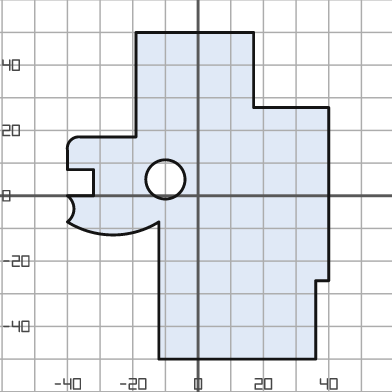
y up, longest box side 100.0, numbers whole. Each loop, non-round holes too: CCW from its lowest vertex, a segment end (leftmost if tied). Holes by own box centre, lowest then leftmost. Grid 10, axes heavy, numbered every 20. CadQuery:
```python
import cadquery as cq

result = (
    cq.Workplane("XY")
    .moveTo(-12.0, -50.0)
    .lineTo(36.0, -50.0)
    .lineTo(36.0, -26.0)
    .lineTo(40.0, -26.0)
    .lineTo(40.0, 27.0)
    .lineTo(17.0, 27.0)
    .lineTo(17.0, 50.0)
    .lineTo(-19.0, 50.0)
    .lineTo(-19.0, 18.0)
    .lineTo(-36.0, 18.0)
    .threePointArc((-39.0, 17.0), (-40.0, 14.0))
    .lineTo(-40.0, 8.0)
    .lineTo(-32.0, 8.0)
    .lineTo(-32.0, 0.0)
    .lineTo(-40.0, 0.0)
    .threePointArc((-38.0, -4.0), (-40.0, -8.0))
    .threePointArc((-26.0, -12.0), (-12.0, -8.0))
    .close()
    .moveTo(-10.0, 5.0)
    .circle(6.0)
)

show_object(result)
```